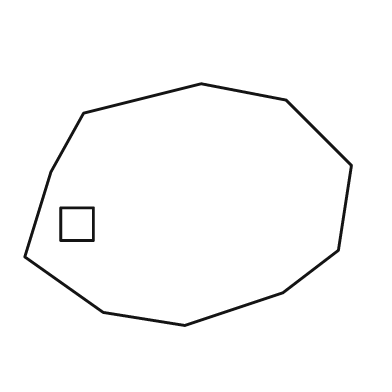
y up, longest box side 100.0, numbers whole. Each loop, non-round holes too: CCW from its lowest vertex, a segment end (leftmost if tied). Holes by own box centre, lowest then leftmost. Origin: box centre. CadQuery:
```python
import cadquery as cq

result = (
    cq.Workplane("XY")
    .moveTo(-1.0, -37.0)
    .lineTo(29.0, -27.0)
    .lineTo(46.0, -14.0)
    .lineTo(50.0, 12.0)
    .lineTo(30.0, 32.0)
    .lineTo(4.0, 37.0)
    .lineTo(-32.0, 28.0)
    .lineTo(-42.0, 10.0)
    .lineTo(-50.0, -16.0)
    .lineTo(-26.0, -33.0)
    .close()
    .moveTo(-39.0, -11.0)
    .lineTo(-29.0, -11.0)
    .lineTo(-29.0, -1.0)
    .lineTo(-39.0, -1.0)
    .close()
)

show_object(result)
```